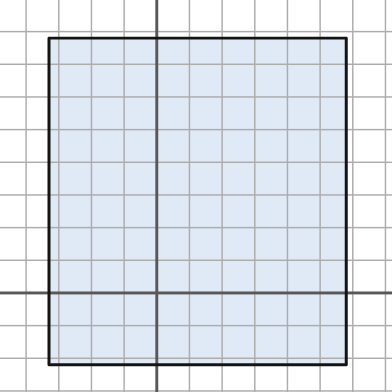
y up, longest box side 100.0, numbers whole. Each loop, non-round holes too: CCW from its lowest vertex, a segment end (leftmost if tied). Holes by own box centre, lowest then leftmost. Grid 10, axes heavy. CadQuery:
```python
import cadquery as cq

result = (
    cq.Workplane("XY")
    .moveTo(-33.0, -22.0)
    .lineTo(58.0, -22.0)
    .lineTo(58.0, 78.0)
    .lineTo(-33.0, 78.0)
    .close()
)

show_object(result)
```